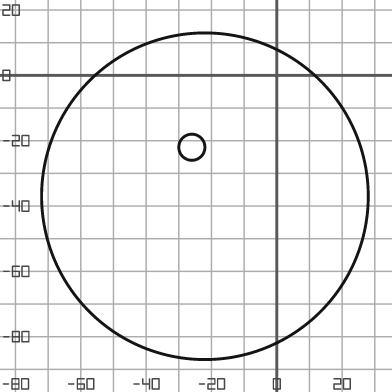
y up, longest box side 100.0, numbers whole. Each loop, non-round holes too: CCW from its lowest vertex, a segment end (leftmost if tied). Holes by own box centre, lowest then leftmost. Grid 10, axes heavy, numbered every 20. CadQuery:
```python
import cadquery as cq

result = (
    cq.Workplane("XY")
    .moveTo(-22.0, -37.0)
    .circle(50.0)
    .moveTo(-26.0, -22.0)
    .circle(4.0)
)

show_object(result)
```